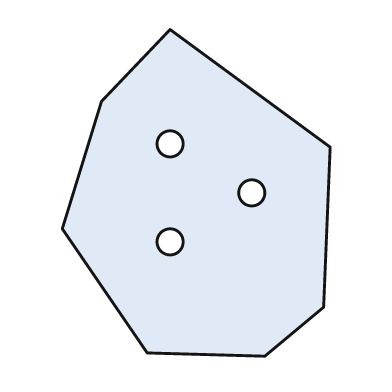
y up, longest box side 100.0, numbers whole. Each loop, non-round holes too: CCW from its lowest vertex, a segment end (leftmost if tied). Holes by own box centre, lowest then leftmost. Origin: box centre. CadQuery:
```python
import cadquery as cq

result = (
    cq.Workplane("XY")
    .moveTo(21.0, -50.0)
    .lineTo(39.0, -35.0)
    .lineTo(41.0, 14.0)
    .lineTo(-8.0, 50.0)
    .lineTo(-29.0, 28.0)
    .lineTo(-41.0, -11.0)
    .lineTo(-15.0, -49.0)
    .close()
    .moveTo(-8.0, -15.0)
    .circle(4.0)
    .moveTo(17.0, 0.0)
    .circle(4.0)
    .moveTo(-8.0, 15.0)
    .circle(4.0)
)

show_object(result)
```